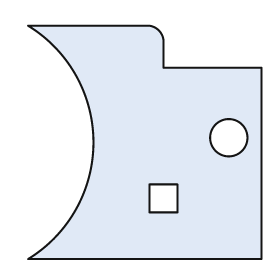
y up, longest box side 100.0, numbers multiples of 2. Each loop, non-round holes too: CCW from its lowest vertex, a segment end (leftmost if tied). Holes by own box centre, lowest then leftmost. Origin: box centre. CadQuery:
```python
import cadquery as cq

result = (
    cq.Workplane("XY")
    .moveTo(-50.0, -50.0)
    .lineTo(50.0, -50.0)
    .lineTo(50.0, 32.0)
    .lineTo(8.0, 32.0)
    .lineTo(8.0, 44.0)
    .threePointArc((6.0, 48.0), (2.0, 50.0))
    .lineTo(-50.0, 50.0)
    .threePointArc((-22.0, 0.0), (-50.0, -50.0))
    .close()
    .moveTo(2.0, -30.0)
    .lineTo(14.0, -30.0)
    .lineTo(14.0, -18.0)
    .lineTo(2.0, -18.0)
    .close()
    .moveTo(36.0, 2.0)
    .circle(8.0)
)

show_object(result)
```